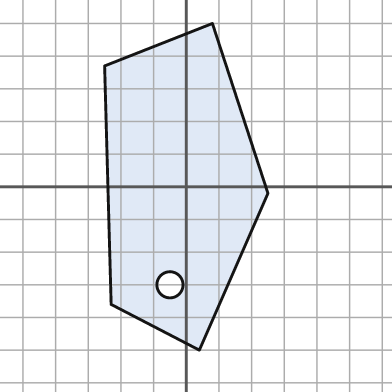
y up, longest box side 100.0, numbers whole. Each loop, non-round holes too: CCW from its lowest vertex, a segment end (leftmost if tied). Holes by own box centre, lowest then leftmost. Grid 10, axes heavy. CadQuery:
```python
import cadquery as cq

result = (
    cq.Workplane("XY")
    .moveTo(4.0, -50.0)
    .lineTo(25.0, -2.0)
    .lineTo(8.0, 50.0)
    .lineTo(-25.0, 37.0)
    .lineTo(-23.0, -36.0)
    .close()
    .moveTo(-5.0, -30.0)
    .circle(4.0)
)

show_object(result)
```